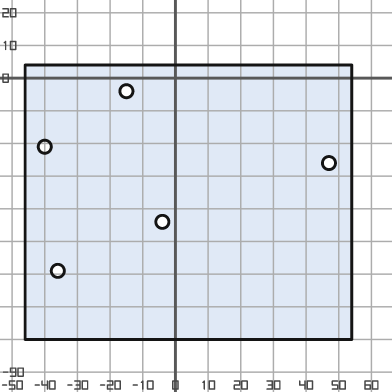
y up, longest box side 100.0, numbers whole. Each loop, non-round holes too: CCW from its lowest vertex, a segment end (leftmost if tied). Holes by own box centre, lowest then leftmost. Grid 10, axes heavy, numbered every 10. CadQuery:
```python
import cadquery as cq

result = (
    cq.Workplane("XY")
    .moveTo(-46.0, -80.0)
    .lineTo(54.0, -80.0)
    .lineTo(54.0, 4.0)
    .lineTo(-46.0, 4.0)
    .close()
    .moveTo(-36.0, -59.0)
    .circle(2.0)
    .moveTo(-4.0, -44.0)
    .circle(2.0)
    .moveTo(47.0, -26.0)
    .circle(2.0)
    .moveTo(-40.0, -21.0)
    .circle(2.0)
    .moveTo(-15.0, -4.0)
    .circle(2.0)
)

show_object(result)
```